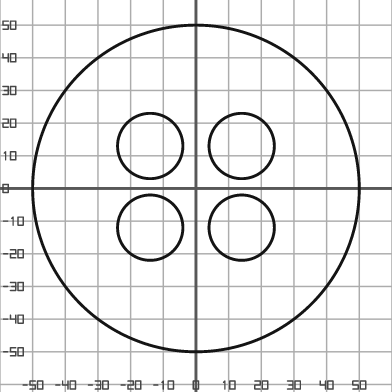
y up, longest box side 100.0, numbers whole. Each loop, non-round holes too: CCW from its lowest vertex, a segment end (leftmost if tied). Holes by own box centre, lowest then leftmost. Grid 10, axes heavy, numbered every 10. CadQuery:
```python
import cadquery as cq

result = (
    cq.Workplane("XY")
    .moveTo(0.0, 0.0)
    .circle(50.0)
    .moveTo(-14.0, -12.0)
    .circle(10.0)
    .moveTo(14.0, -12.0)
    .circle(10.0)
    .moveTo(-14.0, 13.0)
    .circle(10.0)
    .moveTo(14.0, 13.0)
    .circle(10.0)
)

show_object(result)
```